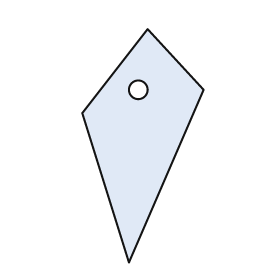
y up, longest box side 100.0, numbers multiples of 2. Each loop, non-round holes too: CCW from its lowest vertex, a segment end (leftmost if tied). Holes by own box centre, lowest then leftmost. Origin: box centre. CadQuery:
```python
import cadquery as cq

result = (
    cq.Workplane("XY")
    .moveTo(-6.0, -50.0)
    .lineTo(26.0, 24.0)
    .lineTo(2.0, 50.0)
    .lineTo(-26.0, 14.0)
    .close()
    .moveTo(-2.0, 24.0)
    .circle(4.0)
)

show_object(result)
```